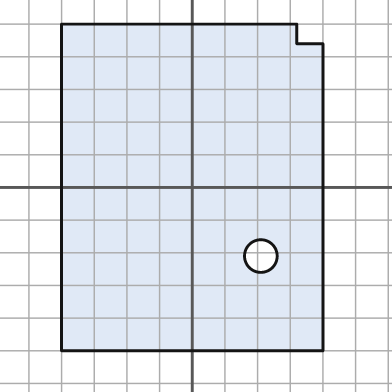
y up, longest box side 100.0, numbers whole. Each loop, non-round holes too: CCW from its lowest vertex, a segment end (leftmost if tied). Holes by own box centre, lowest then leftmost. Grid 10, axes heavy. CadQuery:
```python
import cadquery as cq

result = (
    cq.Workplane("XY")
    .moveTo(-40.0, -50.0)
    .lineTo(40.0, -50.0)
    .lineTo(40.0, 44.0)
    .lineTo(32.0, 44.0)
    .lineTo(32.0, 50.0)
    .lineTo(-40.0, 50.0)
    .close()
    .moveTo(21.0, -21.0)
    .circle(5.0)
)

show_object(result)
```